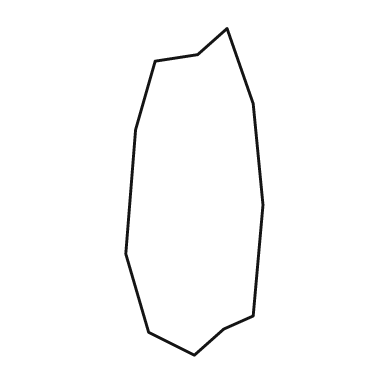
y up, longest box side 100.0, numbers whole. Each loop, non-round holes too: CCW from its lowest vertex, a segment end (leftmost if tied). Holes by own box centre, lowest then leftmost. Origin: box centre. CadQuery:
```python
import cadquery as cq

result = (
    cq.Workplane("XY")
    .moveTo(0.0, -50.0)
    .lineTo(9.0, -42.0)
    .lineTo(18.0, -38.0)
    .lineTo(21.0, -4.0)
    .lineTo(18.0, 27.0)
    .lineTo(10.0, 50.0)
    .lineTo(1.0, 42.0)
    .lineTo(-12.0, 40.0)
    .lineTo(-18.0, 19.0)
    .lineTo(-21.0, -19.0)
    .lineTo(-14.0, -43.0)
    .close()
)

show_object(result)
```